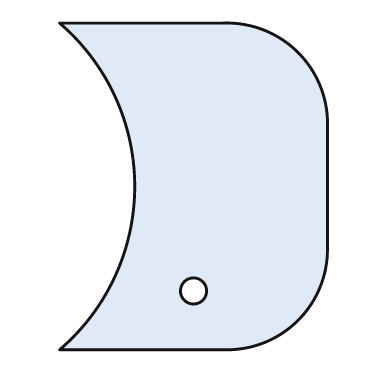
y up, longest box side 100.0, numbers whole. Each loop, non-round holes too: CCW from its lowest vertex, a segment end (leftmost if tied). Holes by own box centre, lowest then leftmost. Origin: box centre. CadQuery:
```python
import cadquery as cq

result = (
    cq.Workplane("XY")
    .moveTo(-41.0, -50.0)
    .lineTo(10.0, -50.0)
    .threePointArc((32.0, -41.0), (41.0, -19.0))
    .lineTo(41.0, 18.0)
    .threePointArc((32.0, 41.0), (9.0, 50.0))
    .lineTo(-41.0, 50.0)
    .threePointArc((-18.0, 0.0), (-41.0, -50.0))
    .close()
    .moveTo(0.0, -32.0)
    .circle(4.0)
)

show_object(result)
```